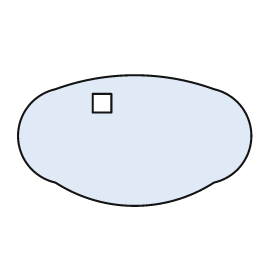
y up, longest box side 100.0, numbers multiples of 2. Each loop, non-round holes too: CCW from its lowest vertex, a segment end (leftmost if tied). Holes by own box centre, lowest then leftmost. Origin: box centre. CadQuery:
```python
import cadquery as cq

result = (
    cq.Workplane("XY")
    .moveTo(-34.0, -18.0)
    .threePointArc((0.0, -28.0), (34.0, -18.0))
    .threePointArc((50.0, 2.0), (34.0, 22.0))
    .threePointArc((0.0, 28.0), (-34.0, 22.0))
    .threePointArc((-50.0, 2.0), (-34.0, -18.0))
    .close()
    .moveTo(-18.0, 12.0)
    .lineTo(-10.0, 12.0)
    .lineTo(-10.0, 20.0)
    .lineTo(-18.0, 20.0)
    .close()
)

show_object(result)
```